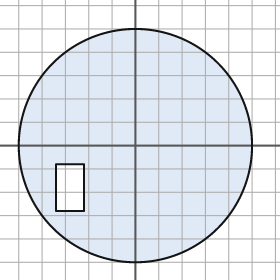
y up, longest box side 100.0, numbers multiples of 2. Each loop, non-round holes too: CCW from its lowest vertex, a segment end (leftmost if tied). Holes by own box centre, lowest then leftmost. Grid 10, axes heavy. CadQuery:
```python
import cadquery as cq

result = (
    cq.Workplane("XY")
    .moveTo(0.0, 0.0)
    .circle(50.0)
    .moveTo(-34.0, -28.0)
    .lineTo(-22.0, -28.0)
    .lineTo(-22.0, -8.0)
    .lineTo(-34.0, -8.0)
    .close()
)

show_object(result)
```